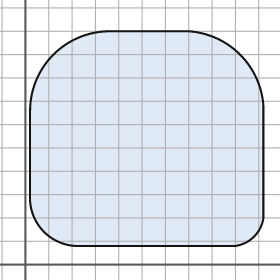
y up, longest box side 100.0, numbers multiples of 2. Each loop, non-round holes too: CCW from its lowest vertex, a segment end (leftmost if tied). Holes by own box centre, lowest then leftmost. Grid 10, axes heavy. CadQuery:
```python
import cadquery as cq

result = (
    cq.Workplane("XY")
    .moveTo(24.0, 8.0)
    .lineTo(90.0, 8.0)
    .threePointArc((98.0, 12.0), (102.0, 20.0))
    .lineTo(102.0, 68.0)
    .threePointArc((92.0, 90.0), (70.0, 100.0))
    .lineTo(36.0, 100.0)
    .threePointArc((12.0, 90.0), (2.0, 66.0))
    .lineTo(2.0, 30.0)
    .threePointArc((8.0, 14.0), (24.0, 8.0))
    .close()
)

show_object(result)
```